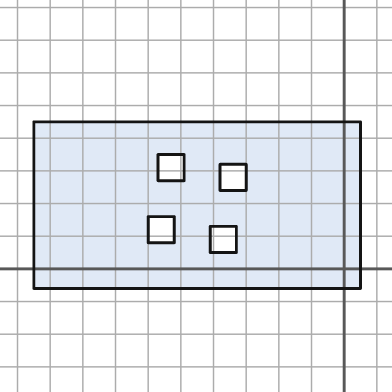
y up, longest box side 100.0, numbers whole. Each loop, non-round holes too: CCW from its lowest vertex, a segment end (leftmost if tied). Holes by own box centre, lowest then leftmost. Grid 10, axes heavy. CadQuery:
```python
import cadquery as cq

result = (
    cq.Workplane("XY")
    .moveTo(-95.0, -6.0)
    .lineTo(5.0, -6.0)
    .lineTo(5.0, 45.0)
    .lineTo(-95.0, 45.0)
    .close()
    .moveTo(-41.0, 5.0)
    .lineTo(-33.0, 5.0)
    .lineTo(-33.0, 13.0)
    .lineTo(-41.0, 13.0)
    .close()
    .moveTo(-60.0, 8.0)
    .lineTo(-52.0, 8.0)
    .lineTo(-52.0, 16.0)
    .lineTo(-60.0, 16.0)
    .close()
    .moveTo(-38.0, 24.0)
    .lineTo(-30.0, 24.0)
    .lineTo(-30.0, 32.0)
    .lineTo(-38.0, 32.0)
    .close()
    .moveTo(-57.0, 27.0)
    .lineTo(-49.0, 27.0)
    .lineTo(-49.0, 35.0)
    .lineTo(-57.0, 35.0)
    .close()
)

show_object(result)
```